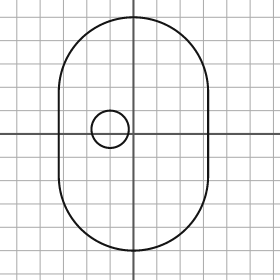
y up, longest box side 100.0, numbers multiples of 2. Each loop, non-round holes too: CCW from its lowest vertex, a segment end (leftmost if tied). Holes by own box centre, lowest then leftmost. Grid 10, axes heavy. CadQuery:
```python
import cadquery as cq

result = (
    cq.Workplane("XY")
    .moveTo(-32.0, -18.0)
    .threePointArc((0.0, -50.0), (32.0, -18.0))
    .lineTo(32.0, 18.0)
    .threePointArc((0.0, 50.0), (-32.0, 18.0))
    .close()
    .moveTo(-10.0, 2.0)
    .circle(8.0)
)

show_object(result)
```